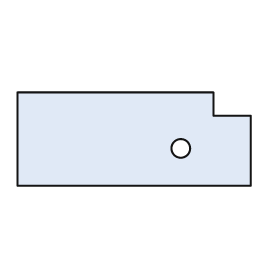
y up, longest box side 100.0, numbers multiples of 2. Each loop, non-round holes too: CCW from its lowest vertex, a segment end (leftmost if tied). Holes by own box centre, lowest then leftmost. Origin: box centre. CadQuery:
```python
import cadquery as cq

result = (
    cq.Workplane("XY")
    .moveTo(-50.0, -20.0)
    .lineTo(50.0, -20.0)
    .lineTo(50.0, 10.0)
    .lineTo(34.0, 10.0)
    .lineTo(34.0, 20.0)
    .lineTo(-50.0, 20.0)
    .close()
    .moveTo(20.0, -4.0)
    .circle(4.0)
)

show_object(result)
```